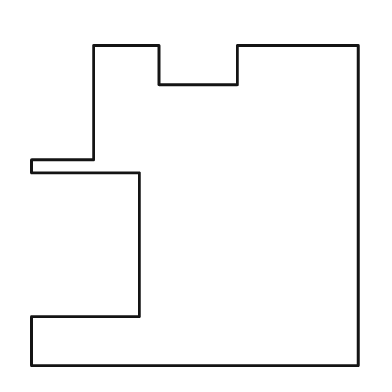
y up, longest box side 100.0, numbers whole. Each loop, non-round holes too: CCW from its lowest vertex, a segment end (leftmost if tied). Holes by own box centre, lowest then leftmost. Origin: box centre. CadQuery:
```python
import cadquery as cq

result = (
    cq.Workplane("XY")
    .moveTo(-50.0, -49.0)
    .lineTo(50.0, -49.0)
    .lineTo(50.0, 49.0)
    .lineTo(13.0, 49.0)
    .lineTo(13.0, 37.0)
    .lineTo(-11.0, 37.0)
    .lineTo(-11.0, 49.0)
    .lineTo(-31.0, 49.0)
    .lineTo(-31.0, 14.0)
    .lineTo(-50.0, 14.0)
    .lineTo(-50.0, 10.0)
    .lineTo(-17.0, 10.0)
    .lineTo(-17.0, -34.0)
    .lineTo(-50.0, -34.0)
    .close()
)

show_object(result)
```